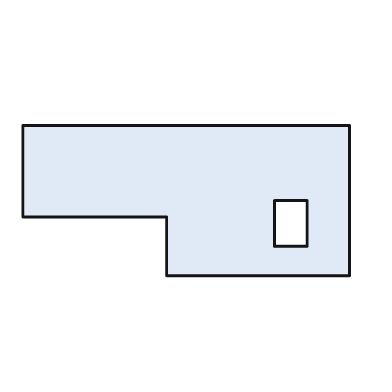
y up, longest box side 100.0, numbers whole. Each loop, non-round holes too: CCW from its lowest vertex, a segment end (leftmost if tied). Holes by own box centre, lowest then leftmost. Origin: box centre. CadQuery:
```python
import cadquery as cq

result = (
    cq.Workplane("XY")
    .moveTo(-6.0, -23.0)
    .lineTo(50.0, -23.0)
    .lineTo(50.0, 23.0)
    .lineTo(-50.0, 23.0)
    .lineTo(-50.0, -5.0)
    .lineTo(-6.0, -5.0)
    .close()
    .moveTo(27.0, -14.0)
    .lineTo(37.0, -14.0)
    .lineTo(37.0, 0.0)
    .lineTo(27.0, 0.0)
    .close()
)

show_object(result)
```